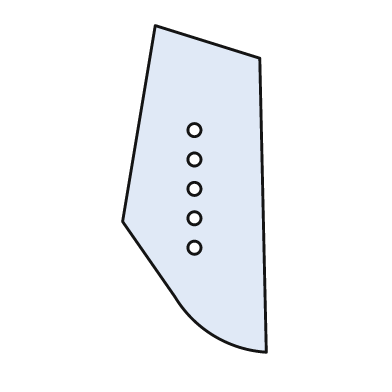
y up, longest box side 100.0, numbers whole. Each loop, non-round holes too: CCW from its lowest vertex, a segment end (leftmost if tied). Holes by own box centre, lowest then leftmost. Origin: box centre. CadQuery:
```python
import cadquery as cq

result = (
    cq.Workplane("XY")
    .moveTo(22.0, -50.0)
    .lineTo(20.0, 40.0)
    .lineTo(-12.0, 50.0)
    .lineTo(-22.0, -10.0)
    .lineTo(-6.0, -33.0)
    .threePointArc((6.0, -45.0), (22.0, -50.0))
    .close()
    .moveTo(0.0, -18.0)
    .circle(2.0)
    .moveTo(0.0, -9.0)
    .circle(2.0)
    .moveTo(0.0, 0.0)
    .circle(2.0)
    .moveTo(0.0, 9.0)
    .circle(2.0)
    .moveTo(0.0, 18.0)
    .circle(2.0)
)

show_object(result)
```